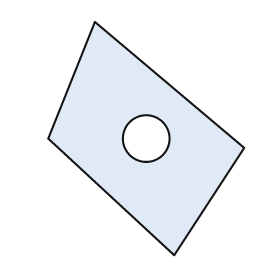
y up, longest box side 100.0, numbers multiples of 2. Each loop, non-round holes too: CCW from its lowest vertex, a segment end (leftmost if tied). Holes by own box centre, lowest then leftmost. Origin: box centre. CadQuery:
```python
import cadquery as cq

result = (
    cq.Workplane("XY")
    .moveTo(12.0, -50.0)
    .lineTo(42.0, -4.0)
    .lineTo(-22.0, 50.0)
    .lineTo(-42.0, 0.0)
    .close()
    .moveTo(0.0, 0.0)
    .circle(10.0)
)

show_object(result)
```